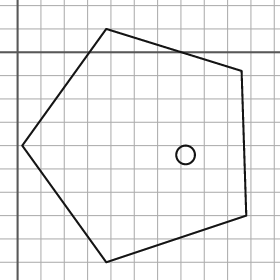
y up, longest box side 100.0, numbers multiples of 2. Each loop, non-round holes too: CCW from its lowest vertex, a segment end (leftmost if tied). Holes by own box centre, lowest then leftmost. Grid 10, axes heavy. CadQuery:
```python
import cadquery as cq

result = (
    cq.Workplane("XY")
    .moveTo(38.0, -90.0)
    .lineTo(98.0, -70.0)
    .lineTo(96.0, -8.0)
    .lineTo(38.0, 10.0)
    .lineTo(2.0, -40.0)
    .close()
    .moveTo(72.0, -44.0)
    .circle(4.0)
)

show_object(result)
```